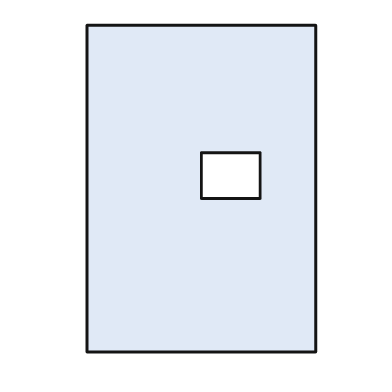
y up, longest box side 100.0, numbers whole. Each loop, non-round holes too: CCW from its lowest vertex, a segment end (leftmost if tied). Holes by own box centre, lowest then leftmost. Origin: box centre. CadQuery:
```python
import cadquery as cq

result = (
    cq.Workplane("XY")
    .moveTo(-35.0, -50.0)
    .lineTo(35.0, -50.0)
    .lineTo(35.0, 50.0)
    .lineTo(-35.0, 50.0)
    .close()
    .moveTo(0.0, -3.0)
    .lineTo(18.0, -3.0)
    .lineTo(18.0, 11.0)
    .lineTo(0.0, 11.0)
    .close()
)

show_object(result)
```